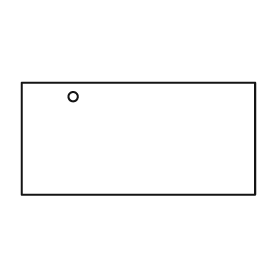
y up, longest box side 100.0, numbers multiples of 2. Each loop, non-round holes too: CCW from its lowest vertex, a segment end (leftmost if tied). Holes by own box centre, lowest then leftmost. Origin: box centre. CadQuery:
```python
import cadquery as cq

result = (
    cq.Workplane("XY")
    .moveTo(-50.0, -24.0)
    .lineTo(50.0, -24.0)
    .lineTo(50.0, 24.0)
    .lineTo(-50.0, 24.0)
    .close()
    .moveTo(-28.0, 18.0)
    .circle(2.0)
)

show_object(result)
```